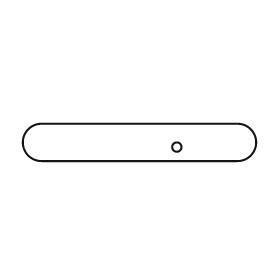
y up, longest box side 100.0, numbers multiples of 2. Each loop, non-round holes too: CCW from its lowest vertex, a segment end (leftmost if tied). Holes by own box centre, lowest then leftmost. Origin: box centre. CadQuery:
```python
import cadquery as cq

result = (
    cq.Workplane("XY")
    .moveTo(-42.0, -8.0)
    .lineTo(42.0, -8.0)
    .threePointArc((50.0, 0.0), (42.0, 8.0))
    .lineTo(-42.0, 8.0)
    .threePointArc((-50.0, 0.0), (-42.0, -8.0))
    .close()
    .moveTo(16.0, -2.0)
    .circle(2.0)
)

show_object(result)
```